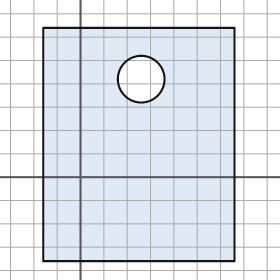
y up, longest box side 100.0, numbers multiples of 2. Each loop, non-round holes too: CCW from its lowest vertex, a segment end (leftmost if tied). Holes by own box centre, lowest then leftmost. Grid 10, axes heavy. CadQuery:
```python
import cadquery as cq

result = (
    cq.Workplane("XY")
    .moveTo(-16.0, -36.0)
    .lineTo(66.0, -36.0)
    .lineTo(66.0, 64.0)
    .lineTo(-16.0, 64.0)
    .close()
    .moveTo(26.0, 42.0)
    .circle(10.0)
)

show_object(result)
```